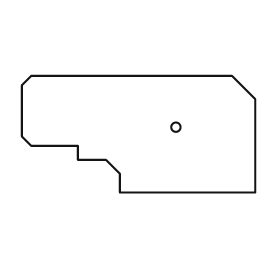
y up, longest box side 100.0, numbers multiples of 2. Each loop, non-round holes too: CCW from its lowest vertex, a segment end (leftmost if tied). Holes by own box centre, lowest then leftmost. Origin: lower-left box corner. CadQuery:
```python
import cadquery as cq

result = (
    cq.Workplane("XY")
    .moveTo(42.0, 0.0)
    .lineTo(100.0, 0.0)
    .lineTo(100.0, 40.0)
    .lineTo(90.0, 50.0)
    .lineTo(4.0, 50.0)
    .lineTo(0.0, 46.0)
    .lineTo(0.0, 24.0)
    .lineTo(4.0, 20.0)
    .lineTo(24.0, 20.0)
    .lineTo(24.0, 14.0)
    .lineTo(36.0, 14.0)
    .lineTo(42.0, 8.0)
    .close()
    .moveTo(66.0, 28.0)
    .circle(2.0)
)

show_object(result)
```